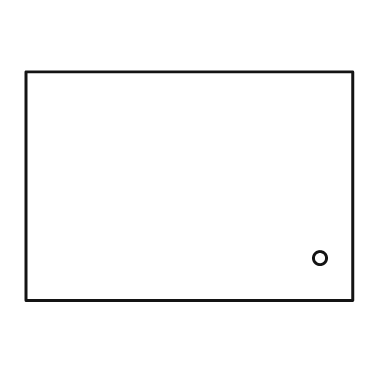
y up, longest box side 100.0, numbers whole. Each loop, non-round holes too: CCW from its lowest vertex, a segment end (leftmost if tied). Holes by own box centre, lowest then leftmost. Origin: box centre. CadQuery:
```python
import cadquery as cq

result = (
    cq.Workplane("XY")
    .moveTo(-50.0, -35.0)
    .lineTo(50.0, -35.0)
    .lineTo(50.0, 35.0)
    .lineTo(-50.0, 35.0)
    .close()
    .moveTo(40.0, -22.0)
    .circle(2.0)
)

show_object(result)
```